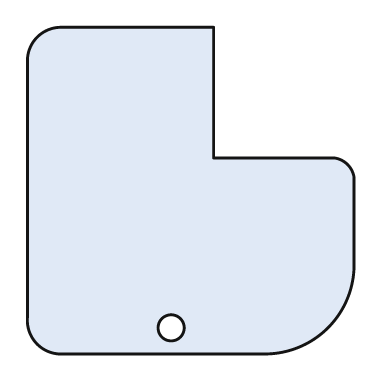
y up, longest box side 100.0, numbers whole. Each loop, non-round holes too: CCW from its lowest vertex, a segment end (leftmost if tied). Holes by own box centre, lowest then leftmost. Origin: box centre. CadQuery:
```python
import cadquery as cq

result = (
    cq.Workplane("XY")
    .moveTo(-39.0, -50.0)
    .lineTo(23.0, -50.0)
    .threePointArc((42.0, -42.0), (50.0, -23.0))
    .lineTo(50.0, 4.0)
    .threePointArc((48.0, 8.0), (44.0, 10.0))
    .lineTo(7.0, 10.0)
    .lineTo(7.0, 50.0)
    .lineTo(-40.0, 50.0)
    .threePointArc((-47.0, 47.0), (-50.0, 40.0))
    .lineTo(-50.0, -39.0)
    .threePointArc((-47.0, -47.0), (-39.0, -50.0))
    .close()
    .moveTo(-6.0, -42.0)
    .circle(4.0)
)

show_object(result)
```